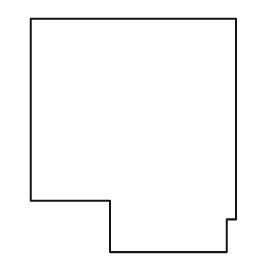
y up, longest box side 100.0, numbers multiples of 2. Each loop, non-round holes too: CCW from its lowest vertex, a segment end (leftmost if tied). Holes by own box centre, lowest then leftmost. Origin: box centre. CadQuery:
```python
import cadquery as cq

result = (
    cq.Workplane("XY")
    .moveTo(-10.0, -50.0)
    .lineTo(40.0, -50.0)
    .lineTo(40.0, -36.0)
    .lineTo(44.0, -36.0)
    .lineTo(44.0, 50.0)
    .lineTo(-44.0, 50.0)
    .lineTo(-44.0, -28.0)
    .lineTo(-10.0, -28.0)
    .close()
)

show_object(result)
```